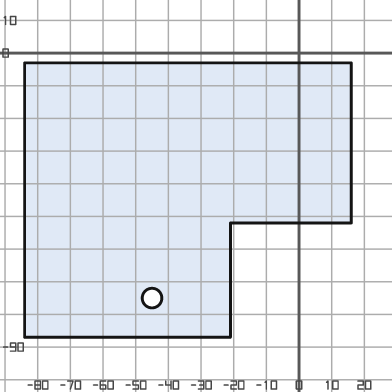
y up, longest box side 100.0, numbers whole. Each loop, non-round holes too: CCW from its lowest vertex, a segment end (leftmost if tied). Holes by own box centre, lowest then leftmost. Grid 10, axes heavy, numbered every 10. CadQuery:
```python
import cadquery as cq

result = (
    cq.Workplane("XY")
    .moveTo(-84.0, -87.0)
    .lineTo(-21.0, -87.0)
    .lineTo(-21.0, -52.0)
    .lineTo(16.0, -52.0)
    .lineTo(16.0, -3.0)
    .lineTo(-84.0, -3.0)
    .close()
    .moveTo(-45.0, -75.0)
    .circle(3.0)
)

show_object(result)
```